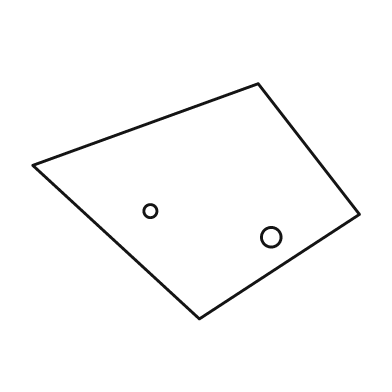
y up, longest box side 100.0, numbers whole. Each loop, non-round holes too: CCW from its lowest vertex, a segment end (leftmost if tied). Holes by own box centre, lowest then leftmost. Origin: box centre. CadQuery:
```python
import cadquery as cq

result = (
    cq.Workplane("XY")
    .moveTo(1.0, -36.0)
    .lineTo(50.0, -4.0)
    .lineTo(19.0, 36.0)
    .lineTo(-50.0, 11.0)
    .close()
    .moveTo(23.0, -11.0)
    .circle(3.0)
    .moveTo(-14.0, -3.0)
    .circle(2.0)
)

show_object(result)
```